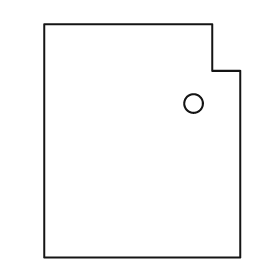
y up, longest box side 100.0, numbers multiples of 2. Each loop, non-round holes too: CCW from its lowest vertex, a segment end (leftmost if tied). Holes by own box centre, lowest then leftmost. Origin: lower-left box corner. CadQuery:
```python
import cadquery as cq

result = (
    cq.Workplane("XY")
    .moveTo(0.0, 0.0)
    .lineTo(84.0, 0.0)
    .lineTo(84.0, 80.0)
    .lineTo(72.0, 80.0)
    .lineTo(72.0, 100.0)
    .lineTo(0.0, 100.0)
    .close()
    .moveTo(64.0, 66.0)
    .circle(4.0)
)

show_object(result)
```